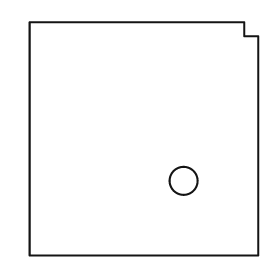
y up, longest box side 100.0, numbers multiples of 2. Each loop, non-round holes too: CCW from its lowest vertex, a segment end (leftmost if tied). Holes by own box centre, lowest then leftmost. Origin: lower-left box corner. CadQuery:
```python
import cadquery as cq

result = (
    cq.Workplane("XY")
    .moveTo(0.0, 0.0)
    .lineTo(98.0, 0.0)
    .lineTo(98.0, 94.0)
    .lineTo(92.0, 94.0)
    .lineTo(92.0, 100.0)
    .lineTo(0.0, 100.0)
    .close()
    .moveTo(66.0, 32.0)
    .circle(6.0)
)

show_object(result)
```